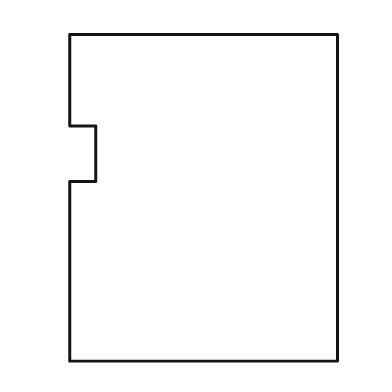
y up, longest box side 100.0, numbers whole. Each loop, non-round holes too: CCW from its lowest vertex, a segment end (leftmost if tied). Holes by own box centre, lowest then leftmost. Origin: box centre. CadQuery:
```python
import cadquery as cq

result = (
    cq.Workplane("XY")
    .moveTo(-41.0, -50.0)
    .lineTo(41.0, -50.0)
    .lineTo(41.0, 50.0)
    .lineTo(-41.0, 50.0)
    .lineTo(-41.0, 22.0)
    .lineTo(-33.0, 22.0)
    .lineTo(-33.0, 5.0)
    .lineTo(-41.0, 5.0)
    .close()
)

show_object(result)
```